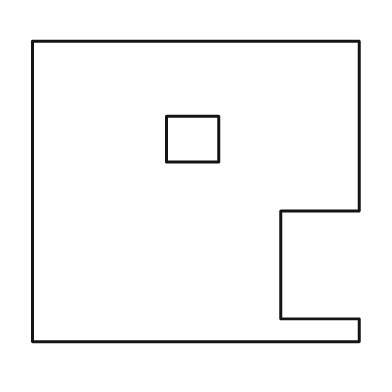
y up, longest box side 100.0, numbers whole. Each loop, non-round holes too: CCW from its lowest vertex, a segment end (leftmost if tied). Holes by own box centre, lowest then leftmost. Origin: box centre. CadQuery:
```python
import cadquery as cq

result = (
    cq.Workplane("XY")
    .moveTo(-50.0, -46.0)
    .lineTo(50.0, -46.0)
    .lineTo(50.0, -39.0)
    .lineTo(26.0, -39.0)
    .lineTo(26.0, -6.0)
    .lineTo(50.0, -6.0)
    .lineTo(50.0, 46.0)
    .lineTo(-50.0, 46.0)
    .close()
    .moveTo(-9.0, 9.0)
    .lineTo(7.0, 9.0)
    .lineTo(7.0, 23.0)
    .lineTo(-9.0, 23.0)
    .close()
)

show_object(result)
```